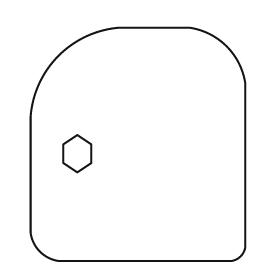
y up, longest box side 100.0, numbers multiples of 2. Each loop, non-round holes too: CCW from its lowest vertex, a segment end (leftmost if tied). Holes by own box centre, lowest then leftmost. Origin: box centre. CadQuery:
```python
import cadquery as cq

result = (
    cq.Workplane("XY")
    .moveTo(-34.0, -50.0)
    .lineTo(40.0, -50.0)
    .threePointArc((44.0, -48.0), (46.0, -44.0))
    .lineTo(46.0, 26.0)
    .threePointArc((38.0, 42.0), (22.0, 50.0))
    .lineTo(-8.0, 50.0)
    .threePointArc((-34.0, 38.0), (-46.0, 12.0))
    .lineTo(-46.0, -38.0)
    .threePointArc((-42.0, -46.0), (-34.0, -50.0))
    .close()
    .moveTo(-26.0, -12.0)
    .lineTo(-20.0, -8.0)
    .lineTo(-20.0, 0.0)
    .lineTo(-26.0, 4.0)
    .lineTo(-32.0, 0.0)
    .lineTo(-32.0, -8.0)
    .close()
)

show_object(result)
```